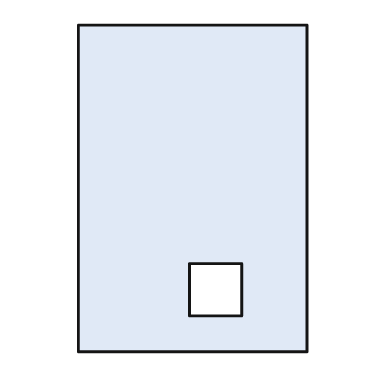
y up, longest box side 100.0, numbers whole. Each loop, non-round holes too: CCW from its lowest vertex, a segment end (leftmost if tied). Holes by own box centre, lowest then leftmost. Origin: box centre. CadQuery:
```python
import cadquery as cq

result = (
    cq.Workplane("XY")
    .moveTo(-35.0, -50.0)
    .lineTo(35.0, -50.0)
    .lineTo(35.0, 50.0)
    .lineTo(-35.0, 50.0)
    .close()
    .moveTo(-1.0, -39.0)
    .lineTo(15.0, -39.0)
    .lineTo(15.0, -23.0)
    .lineTo(-1.0, -23.0)
    .close()
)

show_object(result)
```